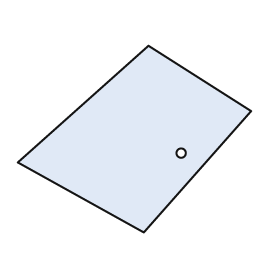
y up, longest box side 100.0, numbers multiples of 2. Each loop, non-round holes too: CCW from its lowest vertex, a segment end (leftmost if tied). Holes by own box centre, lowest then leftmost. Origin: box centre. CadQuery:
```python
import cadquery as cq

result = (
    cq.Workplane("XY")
    .moveTo(4.0, -40.0)
    .lineTo(50.0, 12.0)
    .lineTo(6.0, 40.0)
    .lineTo(-50.0, -10.0)
    .close()
    .moveTo(20.0, -6.0)
    .circle(2.0)
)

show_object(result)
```